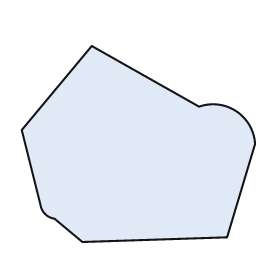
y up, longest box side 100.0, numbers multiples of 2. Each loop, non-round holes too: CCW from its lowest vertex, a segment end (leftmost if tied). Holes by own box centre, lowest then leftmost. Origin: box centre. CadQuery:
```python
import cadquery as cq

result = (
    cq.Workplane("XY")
    .moveTo(-24.0, -42.0)
    .lineTo(38.0, -40.0)
    .lineTo(50.0, 0.0)
    .threePointArc((42.0, 14.0), (26.0, 16.0))
    .lineTo(-20.0, 42.0)
    .lineTo(-50.0, 6.0)
    .lineTo(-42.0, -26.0)
    .threePointArc((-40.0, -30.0), (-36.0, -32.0))
    .close()
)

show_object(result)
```